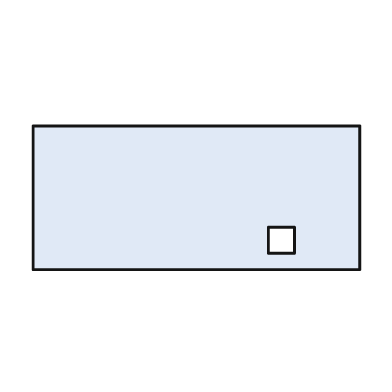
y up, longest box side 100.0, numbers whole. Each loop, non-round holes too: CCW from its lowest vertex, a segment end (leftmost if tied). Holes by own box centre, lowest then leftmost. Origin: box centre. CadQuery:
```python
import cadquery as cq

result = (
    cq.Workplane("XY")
    .moveTo(-50.0, -22.0)
    .lineTo(50.0, -22.0)
    .lineTo(50.0, 22.0)
    .lineTo(-50.0, 22.0)
    .close()
    .moveTo(22.0, -17.0)
    .lineTo(30.0, -17.0)
    .lineTo(30.0, -9.0)
    .lineTo(22.0, -9.0)
    .close()
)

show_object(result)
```